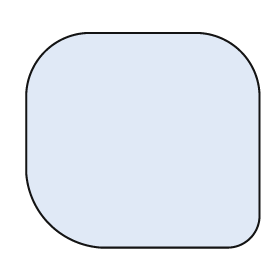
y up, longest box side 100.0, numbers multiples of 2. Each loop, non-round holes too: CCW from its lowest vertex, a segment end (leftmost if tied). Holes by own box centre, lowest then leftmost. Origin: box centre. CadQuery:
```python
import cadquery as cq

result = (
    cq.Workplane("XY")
    .moveTo(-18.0, -46.0)
    .lineTo(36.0, -46.0)
    .threePointArc((46.0, -42.0), (50.0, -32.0))
    .lineTo(50.0, 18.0)
    .threePointArc((42.0, 38.0), (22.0, 46.0))
    .lineTo(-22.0, 46.0)
    .threePointArc((-42.0, 38.0), (-50.0, 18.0))
    .lineTo(-50.0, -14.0)
    .threePointArc((-40.0, -36.0), (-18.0, -46.0))
    .close()
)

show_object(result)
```